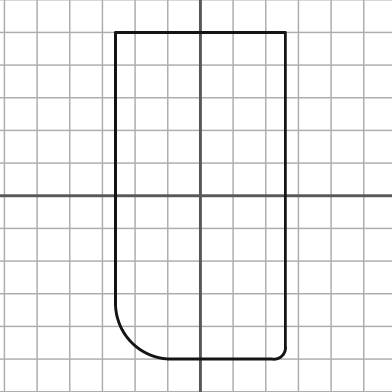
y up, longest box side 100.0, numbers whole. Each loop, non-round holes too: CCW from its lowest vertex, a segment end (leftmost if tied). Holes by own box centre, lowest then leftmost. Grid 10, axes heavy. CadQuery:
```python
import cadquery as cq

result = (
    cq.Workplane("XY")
    .moveTo(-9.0, -50.0)
    .lineTo(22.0, -50.0)
    .threePointArc((25.0, -49.0), (26.0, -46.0))
    .lineTo(26.0, 50.0)
    .lineTo(-26.0, 50.0)
    .lineTo(-26.0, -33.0)
    .threePointArc((-21.0, -45.0), (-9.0, -50.0))
    .close()
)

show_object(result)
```